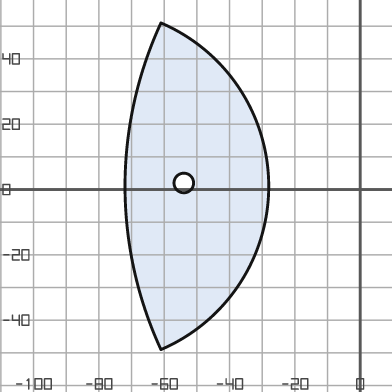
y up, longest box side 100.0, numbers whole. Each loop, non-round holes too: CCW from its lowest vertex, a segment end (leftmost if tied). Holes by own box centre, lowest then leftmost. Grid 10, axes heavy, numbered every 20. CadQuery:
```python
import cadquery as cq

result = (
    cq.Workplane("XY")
    .moveTo(-61.0, -49.0)
    .threePointArc((-28.0, 1.0), (-61.0, 51.0))
    .threePointArc((-72.0, 1.0), (-61.0, -49.0))
    .close()
    .moveTo(-54.0, 2.0)
    .circle(3.0)
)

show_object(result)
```